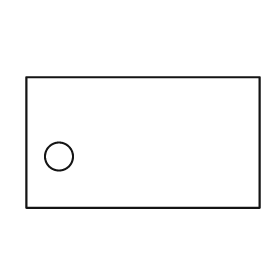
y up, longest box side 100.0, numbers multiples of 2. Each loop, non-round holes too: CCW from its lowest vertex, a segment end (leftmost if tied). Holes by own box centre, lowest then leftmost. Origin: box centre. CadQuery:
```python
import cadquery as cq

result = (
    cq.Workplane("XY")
    .moveTo(-50.0, -28.0)
    .lineTo(50.0, -28.0)
    .lineTo(50.0, 28.0)
    .lineTo(-50.0, 28.0)
    .close()
    .moveTo(-36.0, -6.0)
    .circle(6.0)
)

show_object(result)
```